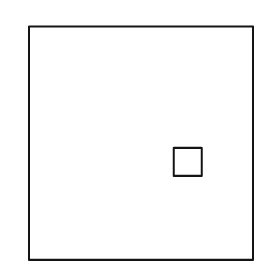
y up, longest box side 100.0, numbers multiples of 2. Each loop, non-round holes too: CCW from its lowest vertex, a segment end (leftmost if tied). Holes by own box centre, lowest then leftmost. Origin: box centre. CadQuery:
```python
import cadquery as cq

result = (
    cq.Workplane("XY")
    .moveTo(-48.0, -50.0)
    .lineTo(48.0, -50.0)
    .lineTo(48.0, 50.0)
    .lineTo(-48.0, 50.0)
    .close()
    .moveTo(14.0, -14.0)
    .lineTo(26.0, -14.0)
    .lineTo(26.0, -2.0)
    .lineTo(14.0, -2.0)
    .close()
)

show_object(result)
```